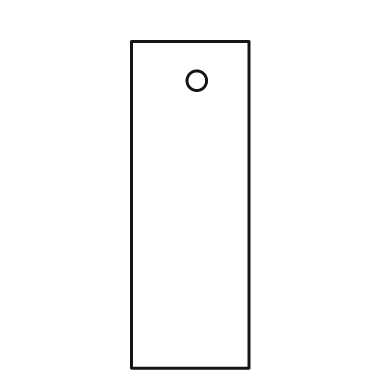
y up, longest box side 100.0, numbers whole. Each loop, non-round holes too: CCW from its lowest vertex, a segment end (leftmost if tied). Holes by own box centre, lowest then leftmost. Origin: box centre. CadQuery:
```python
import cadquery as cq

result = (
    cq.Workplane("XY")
    .moveTo(-18.0, -50.0)
    .lineTo(18.0, -50.0)
    .lineTo(18.0, 50.0)
    .lineTo(-18.0, 50.0)
    .close()
    .moveTo(2.0, 38.0)
    .circle(3.0)
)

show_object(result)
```